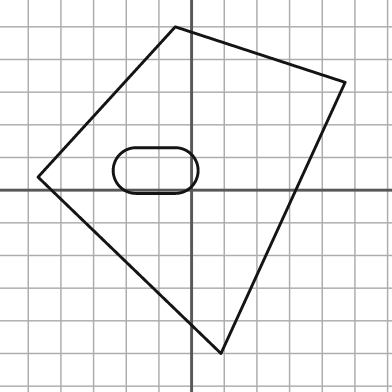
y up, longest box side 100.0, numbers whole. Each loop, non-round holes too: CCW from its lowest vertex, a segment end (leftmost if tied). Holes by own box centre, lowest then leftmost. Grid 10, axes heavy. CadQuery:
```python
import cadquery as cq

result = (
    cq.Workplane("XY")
    .moveTo(9.0, -50.0)
    .lineTo(47.0, 33.0)
    .lineTo(-5.0, 50.0)
    .lineTo(-47.0, 4.0)
    .close()
    .moveTo(-17.0, -1.0)
    .lineTo(-5.0, -1.0)
    .threePointArc((2.0, 6.0), (-5.0, 13.0))
    .lineTo(-17.0, 13.0)
    .threePointArc((-24.0, 6.0), (-17.0, -1.0))
    .close()
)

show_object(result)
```